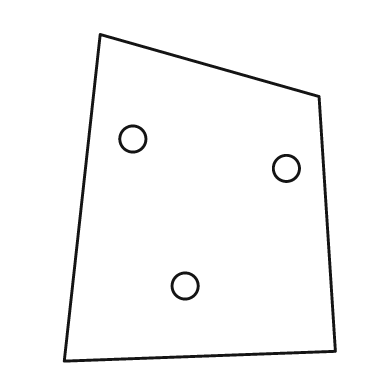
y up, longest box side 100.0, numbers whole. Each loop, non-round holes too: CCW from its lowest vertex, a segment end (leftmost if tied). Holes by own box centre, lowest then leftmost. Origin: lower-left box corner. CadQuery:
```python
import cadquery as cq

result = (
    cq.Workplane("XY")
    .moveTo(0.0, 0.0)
    .lineTo(83.0, 3.0)
    .lineTo(78.0, 81.0)
    .lineTo(11.0, 100.0)
    .close()
    .moveTo(37.0, 23.0)
    .circle(4.0)
    .moveTo(68.0, 59.0)
    .circle(4.0)
    .moveTo(21.0, 68.0)
    .circle(4.0)
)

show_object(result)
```